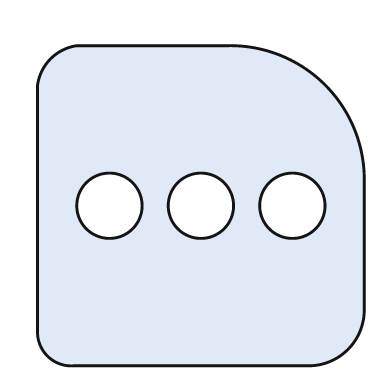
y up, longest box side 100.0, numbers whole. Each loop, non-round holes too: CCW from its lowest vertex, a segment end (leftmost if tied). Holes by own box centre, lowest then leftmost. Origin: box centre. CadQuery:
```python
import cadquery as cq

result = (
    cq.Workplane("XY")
    .moveTo(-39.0, -49.0)
    .lineTo(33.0, -49.0)
    .threePointArc((45.0, -44.0), (50.0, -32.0))
    .lineTo(50.0, 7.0)
    .threePointArc((38.0, 37.0), (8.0, 49.0))
    .lineTo(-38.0, 49.0)
    .threePointArc((-46.0, 45.0), (-50.0, 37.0))
    .lineTo(-50.0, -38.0)
    .threePointArc((-47.0, -46.0), (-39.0, -49.0))
    .close()
    .moveTo(-28.0, 0.0)
    .circle(10.0)
    .moveTo(0.0, 0.0)
    .circle(10.0)
    .moveTo(28.0, 0.0)
    .circle(10.0)
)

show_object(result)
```